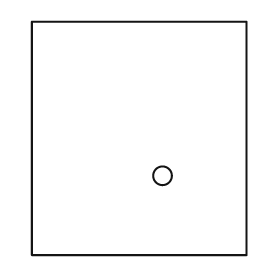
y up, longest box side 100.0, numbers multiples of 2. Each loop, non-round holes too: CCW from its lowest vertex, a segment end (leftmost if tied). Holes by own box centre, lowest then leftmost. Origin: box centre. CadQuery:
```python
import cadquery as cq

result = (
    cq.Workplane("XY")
    .moveTo(-46.0, -50.0)
    .lineTo(46.0, -50.0)
    .lineTo(46.0, 50.0)
    .lineTo(-46.0, 50.0)
    .close()
    .moveTo(10.0, -16.0)
    .circle(4.0)
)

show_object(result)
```